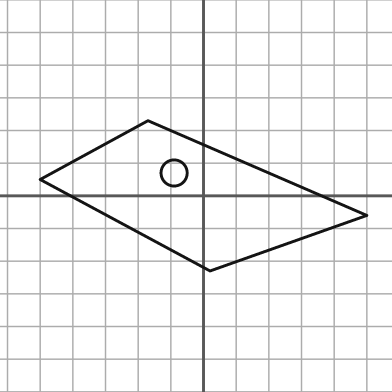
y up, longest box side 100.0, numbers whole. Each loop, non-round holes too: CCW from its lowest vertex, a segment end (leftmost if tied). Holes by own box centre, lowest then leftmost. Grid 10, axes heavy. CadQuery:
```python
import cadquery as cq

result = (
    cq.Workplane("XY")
    .moveTo(2.0, -23.0)
    .lineTo(50.0, -6.0)
    .lineTo(-17.0, 23.0)
    .lineTo(-50.0, 5.0)
    .close()
    .moveTo(-9.0, 7.0)
    .circle(4.0)
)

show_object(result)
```